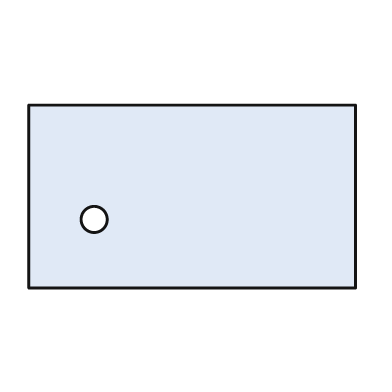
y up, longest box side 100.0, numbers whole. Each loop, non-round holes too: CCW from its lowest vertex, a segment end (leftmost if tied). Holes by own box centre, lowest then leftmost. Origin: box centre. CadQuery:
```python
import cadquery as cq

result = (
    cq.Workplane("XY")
    .moveTo(-50.0, -28.0)
    .lineTo(50.0, -28.0)
    .lineTo(50.0, 28.0)
    .lineTo(-50.0, 28.0)
    .close()
    .moveTo(-30.0, -7.0)
    .circle(4.0)
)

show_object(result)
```